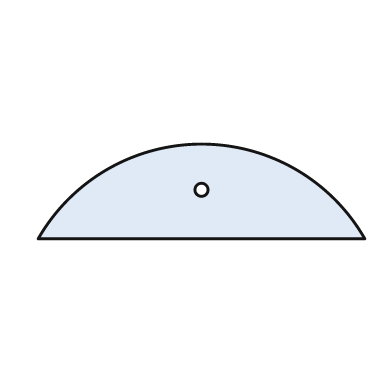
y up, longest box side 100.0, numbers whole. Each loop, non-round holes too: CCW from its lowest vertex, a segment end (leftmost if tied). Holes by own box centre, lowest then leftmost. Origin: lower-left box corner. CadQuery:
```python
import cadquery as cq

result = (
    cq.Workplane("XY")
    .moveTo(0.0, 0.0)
    .lineTo(100.0, 0.0)
    .threePointArc((50.0, 29.0), (0.0, 0.0))
    .close()
    .moveTo(50.0, 15.0)
    .circle(2.0)
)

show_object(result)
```